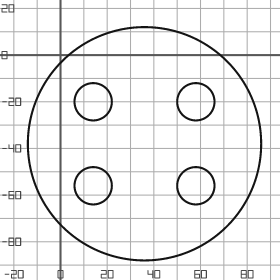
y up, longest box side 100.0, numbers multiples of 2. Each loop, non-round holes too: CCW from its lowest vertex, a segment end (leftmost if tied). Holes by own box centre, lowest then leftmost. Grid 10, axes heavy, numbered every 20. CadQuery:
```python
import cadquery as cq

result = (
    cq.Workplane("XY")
    .moveTo(36.0, -38.0)
    .circle(50.0)
    .moveTo(14.0, -56.0)
    .circle(8.0)
    .moveTo(58.0, -56.0)
    .circle(8.0)
    .moveTo(14.0, -20.0)
    .circle(8.0)
    .moveTo(58.0, -20.0)
    .circle(8.0)
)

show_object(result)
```